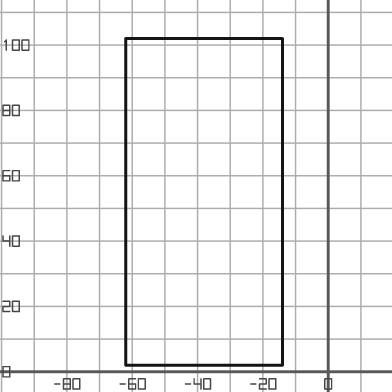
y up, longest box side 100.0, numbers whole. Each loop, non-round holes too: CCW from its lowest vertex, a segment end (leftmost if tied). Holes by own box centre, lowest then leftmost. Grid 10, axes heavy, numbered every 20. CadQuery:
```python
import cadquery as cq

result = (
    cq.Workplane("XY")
    .moveTo(-62.0, 2.0)
    .lineTo(-14.0, 2.0)
    .lineTo(-14.0, 102.0)
    .lineTo(-62.0, 102.0)
    .close()
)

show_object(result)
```